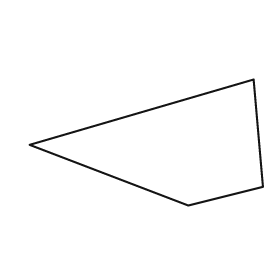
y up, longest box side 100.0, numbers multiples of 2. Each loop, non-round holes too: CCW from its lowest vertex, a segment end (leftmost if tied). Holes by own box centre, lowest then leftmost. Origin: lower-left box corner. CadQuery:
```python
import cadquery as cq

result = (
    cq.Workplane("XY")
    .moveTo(68.0, 0.0)
    .lineTo(100.0, 8.0)
    .lineTo(96.0, 54.0)
    .lineTo(0.0, 26.0)
    .close()
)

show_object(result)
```